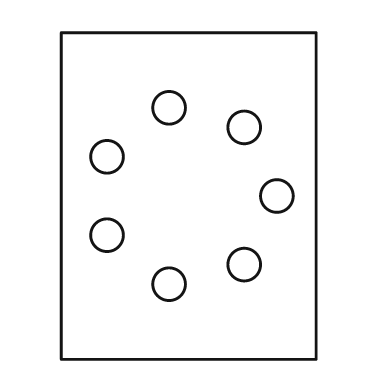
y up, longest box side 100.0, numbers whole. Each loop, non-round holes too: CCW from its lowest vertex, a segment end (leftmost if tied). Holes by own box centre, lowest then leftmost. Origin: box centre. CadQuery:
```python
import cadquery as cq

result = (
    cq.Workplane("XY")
    .moveTo(-39.0, -50.0)
    .lineTo(39.0, -50.0)
    .lineTo(39.0, 50.0)
    .lineTo(-39.0, 50.0)
    .close()
    .moveTo(-6.0, -27.0)
    .circle(5.0)
    .moveTo(17.0, -21.0)
    .circle(5.0)
    .moveTo(-25.0, -12.0)
    .circle(5.0)
    .moveTo(27.0, 0.0)
    .circle(5.0)
    .moveTo(-25.0, 12.0)
    .circle(5.0)
    .moveTo(17.0, 21.0)
    .circle(5.0)
    .moveTo(-6.0, 27.0)
    .circle(5.0)
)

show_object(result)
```